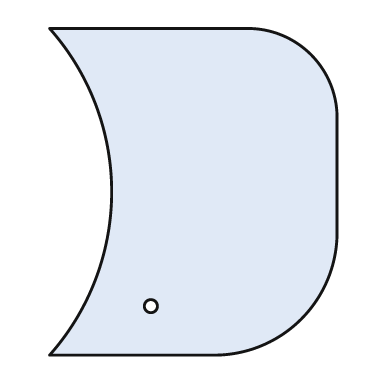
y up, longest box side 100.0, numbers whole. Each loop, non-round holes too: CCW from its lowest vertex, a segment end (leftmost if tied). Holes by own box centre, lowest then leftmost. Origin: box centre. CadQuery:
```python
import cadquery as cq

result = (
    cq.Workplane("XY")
    .moveTo(-44.0, -50.0)
    .lineTo(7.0, -50.0)
    .threePointArc((33.0, -39.0), (44.0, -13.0))
    .lineTo(44.0, 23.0)
    .threePointArc((36.0, 42.0), (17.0, 50.0))
    .lineTo(-44.0, 50.0)
    .threePointArc((-25.0, 0.0), (-44.0, -50.0))
    .close()
    .moveTo(-13.0, -35.0)
    .circle(2.0)
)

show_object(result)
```